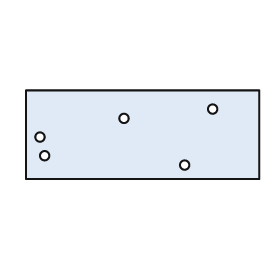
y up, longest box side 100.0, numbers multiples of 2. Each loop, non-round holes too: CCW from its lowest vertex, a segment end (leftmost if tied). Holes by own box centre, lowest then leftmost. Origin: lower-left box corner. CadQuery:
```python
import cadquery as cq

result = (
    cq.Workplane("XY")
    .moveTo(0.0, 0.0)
    .lineTo(100.0, 0.0)
    .lineTo(100.0, 38.0)
    .lineTo(0.0, 38.0)
    .close()
    .moveTo(68.0, 6.0)
    .circle(2.0)
    .moveTo(8.0, 10.0)
    .circle(2.0)
    .moveTo(6.0, 18.0)
    .circle(2.0)
    .moveTo(42.0, 26.0)
    .circle(2.0)
    .moveTo(80.0, 30.0)
    .circle(2.0)
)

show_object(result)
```